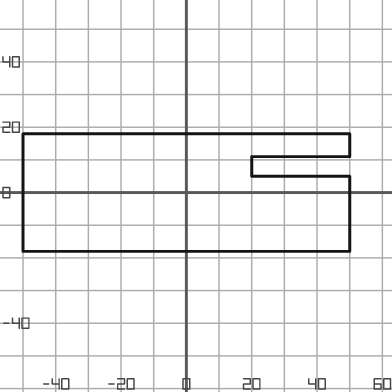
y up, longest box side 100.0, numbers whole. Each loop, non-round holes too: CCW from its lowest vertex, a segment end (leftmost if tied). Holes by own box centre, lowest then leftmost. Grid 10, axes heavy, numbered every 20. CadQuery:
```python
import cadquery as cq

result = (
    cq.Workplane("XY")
    .moveTo(-50.0, -18.0)
    .lineTo(50.0, -18.0)
    .lineTo(50.0, 5.0)
    .lineTo(20.0, 5.0)
    .lineTo(20.0, 11.0)
    .lineTo(50.0, 11.0)
    .lineTo(50.0, 18.0)
    .lineTo(-50.0, 18.0)
    .close()
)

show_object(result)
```